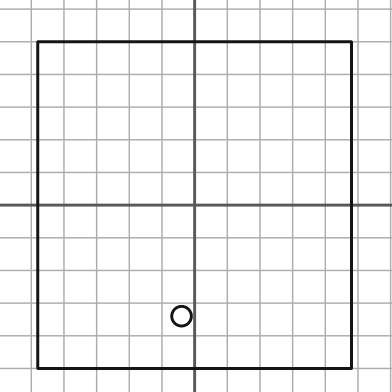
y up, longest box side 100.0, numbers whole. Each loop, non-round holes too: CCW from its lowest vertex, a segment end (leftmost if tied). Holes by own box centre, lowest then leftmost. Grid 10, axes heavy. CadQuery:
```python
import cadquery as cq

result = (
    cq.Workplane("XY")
    .moveTo(-48.0, -50.0)
    .lineTo(48.0, -50.0)
    .lineTo(48.0, 50.0)
    .lineTo(-48.0, 50.0)
    .close()
    .moveTo(-4.0, -34.0)
    .circle(3.0)
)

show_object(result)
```